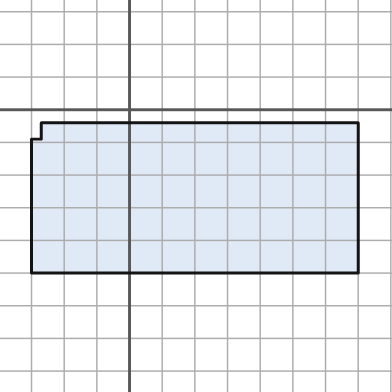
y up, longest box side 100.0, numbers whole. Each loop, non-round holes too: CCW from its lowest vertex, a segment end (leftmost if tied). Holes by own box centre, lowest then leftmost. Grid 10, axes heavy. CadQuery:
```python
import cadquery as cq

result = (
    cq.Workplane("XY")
    .moveTo(-30.0, -50.0)
    .lineTo(70.0, -50.0)
    .lineTo(70.0, -4.0)
    .lineTo(-27.0, -4.0)
    .lineTo(-27.0, -9.0)
    .lineTo(-30.0, -9.0)
    .close()
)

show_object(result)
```